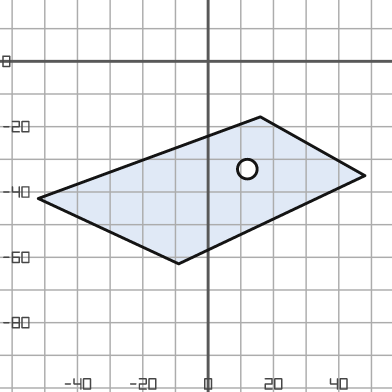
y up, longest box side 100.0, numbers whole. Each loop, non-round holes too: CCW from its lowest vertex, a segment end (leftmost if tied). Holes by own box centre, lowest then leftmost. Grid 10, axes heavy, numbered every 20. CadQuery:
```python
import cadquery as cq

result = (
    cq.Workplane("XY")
    .moveTo(-9.0, -62.0)
    .lineTo(48.0, -35.0)
    .lineTo(16.0, -17.0)
    .lineTo(-52.0, -42.0)
    .close()
    .moveTo(12.0, -33.0)
    .circle(3.0)
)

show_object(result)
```